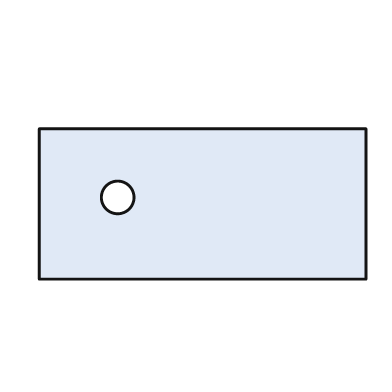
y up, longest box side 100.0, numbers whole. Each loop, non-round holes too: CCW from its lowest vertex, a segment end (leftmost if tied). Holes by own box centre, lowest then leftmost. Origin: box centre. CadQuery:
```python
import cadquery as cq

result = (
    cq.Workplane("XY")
    .moveTo(-50.0, -23.0)
    .lineTo(50.0, -23.0)
    .lineTo(50.0, 23.0)
    .lineTo(-50.0, 23.0)
    .close()
    .moveTo(-26.0, 2.0)
    .circle(5.0)
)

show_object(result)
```